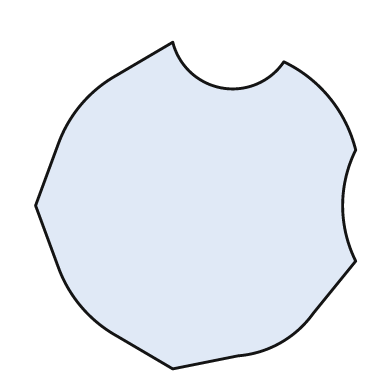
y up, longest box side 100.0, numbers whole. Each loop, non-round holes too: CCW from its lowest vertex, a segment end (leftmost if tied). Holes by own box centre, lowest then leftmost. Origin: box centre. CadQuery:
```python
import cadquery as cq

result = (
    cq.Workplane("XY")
    .moveTo(-7.0, -50.0)
    .lineTo(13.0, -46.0)
    .threePointArc((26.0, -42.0), (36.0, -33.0))
    .lineTo(49.0, -17.0)
    .threePointArc((45.0, 0.0), (49.0, 17.0))
    .threePointArc((41.0, 33.0), (27.0, 44.0))
    .threePointArc((8.0, 36.0), (-7.0, 50.0))
    .lineTo(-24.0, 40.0)
    .threePointArc((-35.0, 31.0), (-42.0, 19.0))
    .lineTo(-49.0, 0.0)
    .lineTo(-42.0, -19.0)
    .threePointArc((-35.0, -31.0), (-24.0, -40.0))
    .close()
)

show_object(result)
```